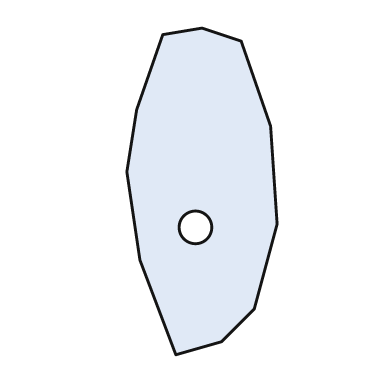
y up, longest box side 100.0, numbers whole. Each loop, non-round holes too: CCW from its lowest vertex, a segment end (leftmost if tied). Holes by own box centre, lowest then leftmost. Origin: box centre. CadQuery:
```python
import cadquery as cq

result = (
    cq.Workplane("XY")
    .moveTo(-8.0, -50.0)
    .lineTo(6.0, -46.0)
    .lineTo(16.0, -36.0)
    .lineTo(23.0, -10.0)
    .lineTo(21.0, 20.0)
    .lineTo(12.0, 46.0)
    .lineTo(0.0, 50.0)
    .lineTo(-12.0, 48.0)
    .lineTo(-20.0, 25.0)
    .lineTo(-23.0, 6.0)
    .lineTo(-19.0, -21.0)
    .close()
    .moveTo(-2.0, -11.0)
    .circle(5.0)
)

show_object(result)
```